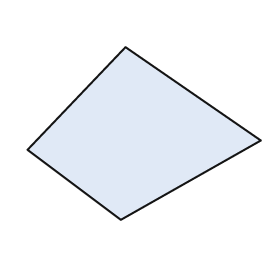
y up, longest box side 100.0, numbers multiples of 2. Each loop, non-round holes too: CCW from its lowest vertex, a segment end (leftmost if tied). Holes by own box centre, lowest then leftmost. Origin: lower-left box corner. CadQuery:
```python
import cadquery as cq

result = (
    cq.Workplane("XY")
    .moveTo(40.0, 0.0)
    .lineTo(100.0, 34.0)
    .lineTo(42.0, 74.0)
    .lineTo(0.0, 30.0)
    .close()
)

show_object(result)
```